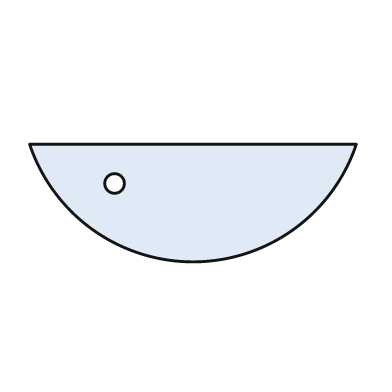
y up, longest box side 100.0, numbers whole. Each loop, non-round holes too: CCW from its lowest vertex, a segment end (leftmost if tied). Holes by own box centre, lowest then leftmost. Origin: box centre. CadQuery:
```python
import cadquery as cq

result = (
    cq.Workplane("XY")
    .moveTo(-50.0, 18.0)
    .threePointArc((0.0, -18.0), (50.0, 18.0))
    .close()
    .moveTo(-24.0, 6.0)
    .circle(3.0)
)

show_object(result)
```